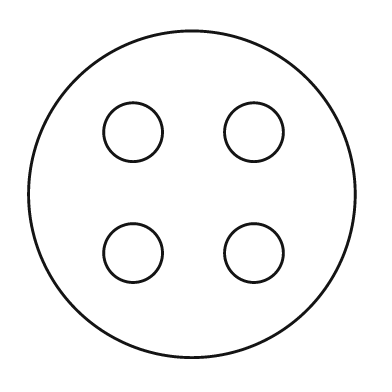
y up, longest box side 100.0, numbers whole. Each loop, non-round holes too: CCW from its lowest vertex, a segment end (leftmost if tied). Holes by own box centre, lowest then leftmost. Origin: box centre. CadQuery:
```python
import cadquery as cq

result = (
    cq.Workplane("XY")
    .moveTo(0.0, 0.0)
    .circle(50.0)
    .moveTo(-18.0, -18.0)
    .circle(9.0)
    .moveTo(19.0, -18.0)
    .circle(9.0)
    .moveTo(-18.0, 19.0)
    .circle(9.0)
    .moveTo(19.0, 19.0)
    .circle(9.0)
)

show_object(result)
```